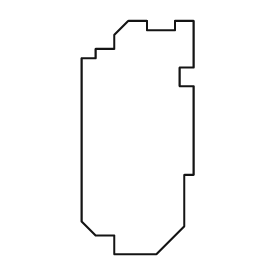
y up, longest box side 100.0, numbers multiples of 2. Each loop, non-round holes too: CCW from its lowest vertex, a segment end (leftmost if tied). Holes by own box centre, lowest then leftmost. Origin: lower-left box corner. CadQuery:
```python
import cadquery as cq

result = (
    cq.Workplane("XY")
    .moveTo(14.0, 0.0)
    .lineTo(32.0, 0.0)
    .lineTo(44.0, 12.0)
    .lineTo(44.0, 34.0)
    .lineTo(48.0, 34.0)
    .lineTo(48.0, 72.0)
    .lineTo(42.0, 72.0)
    .lineTo(42.0, 80.0)
    .lineTo(48.0, 80.0)
    .lineTo(48.0, 100.0)
    .lineTo(40.0, 100.0)
    .lineTo(40.0, 96.0)
    .lineTo(28.0, 96.0)
    .lineTo(28.0, 100.0)
    .lineTo(20.0, 100.0)
    .lineTo(14.0, 94.0)
    .lineTo(14.0, 88.0)
    .lineTo(6.0, 88.0)
    .lineTo(6.0, 84.0)
    .lineTo(0.0, 84.0)
    .lineTo(0.0, 14.0)
    .lineTo(6.0, 8.0)
    .lineTo(14.0, 8.0)
    .close()
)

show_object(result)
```